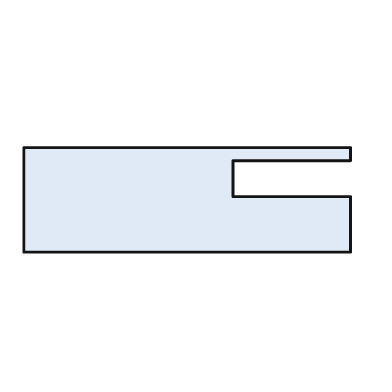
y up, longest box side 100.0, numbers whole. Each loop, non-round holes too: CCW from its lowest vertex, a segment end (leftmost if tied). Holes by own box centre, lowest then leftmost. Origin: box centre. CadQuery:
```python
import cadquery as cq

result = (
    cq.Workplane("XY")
    .moveTo(-50.0, -16.0)
    .lineTo(50.0, -16.0)
    .lineTo(50.0, 1.0)
    .lineTo(14.0, 1.0)
    .lineTo(14.0, 12.0)
    .lineTo(50.0, 12.0)
    .lineTo(50.0, 16.0)
    .lineTo(-50.0, 16.0)
    .close()
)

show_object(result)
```